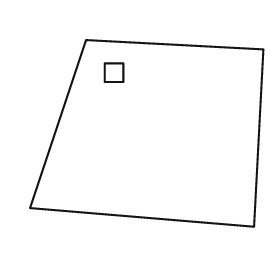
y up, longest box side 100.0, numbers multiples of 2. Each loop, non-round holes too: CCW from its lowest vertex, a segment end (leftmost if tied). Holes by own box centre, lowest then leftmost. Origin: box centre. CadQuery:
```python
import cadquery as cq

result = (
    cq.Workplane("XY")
    .moveTo(46.0, -40.0)
    .lineTo(50.0, 36.0)
    .lineTo(-26.0, 40.0)
    .lineTo(-50.0, -32.0)
    .close()
    .moveTo(-18.0, 22.0)
    .lineTo(-10.0, 22.0)
    .lineTo(-10.0, 30.0)
    .lineTo(-18.0, 30.0)
    .close()
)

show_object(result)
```